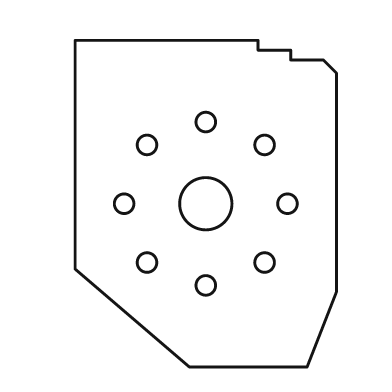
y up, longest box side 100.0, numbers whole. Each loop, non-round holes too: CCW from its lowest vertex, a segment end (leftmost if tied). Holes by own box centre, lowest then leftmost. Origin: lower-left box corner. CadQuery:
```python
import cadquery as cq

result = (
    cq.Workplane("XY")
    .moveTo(35.0, 0.0)
    .lineTo(71.0, 0.0)
    .lineTo(80.0, 23.0)
    .lineTo(80.0, 90.0)
    .lineTo(76.0, 94.0)
    .lineTo(66.0, 94.0)
    .lineTo(66.0, 97.0)
    .lineTo(56.0, 97.0)
    .lineTo(56.0, 100.0)
    .lineTo(0.0, 100.0)
    .lineTo(0.0, 30.0)
    .close()
    .moveTo(40.0, 25.0)
    .circle(3.0)
    .moveTo(22.0, 32.0)
    .circle(3.0)
    .moveTo(58.0, 32.0)
    .circle(3.0)
    .moveTo(15.0, 50.0)
    .circle(3.0)
    .moveTo(40.0, 50.0)
    .circle(8.0)
    .moveTo(65.0, 50.0)
    .circle(3.0)
    .moveTo(22.0, 68.0)
    .circle(3.0)
    .moveTo(58.0, 68.0)
    .circle(3.0)
    .moveTo(40.0, 75.0)
    .circle(3.0)
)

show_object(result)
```